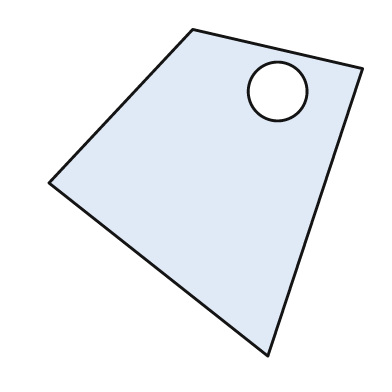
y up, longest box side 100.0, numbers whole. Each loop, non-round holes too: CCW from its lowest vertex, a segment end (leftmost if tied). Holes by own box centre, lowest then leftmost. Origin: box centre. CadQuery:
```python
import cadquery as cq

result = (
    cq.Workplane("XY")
    .moveTo(19.0, -50.0)
    .lineTo(48.0, 38.0)
    .lineTo(-4.0, 50.0)
    .lineTo(-48.0, 3.0)
    .close()
    .moveTo(22.0, 31.0)
    .circle(9.0)
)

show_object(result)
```